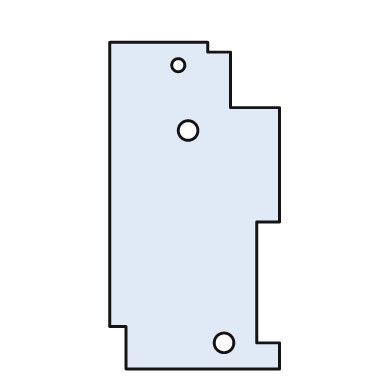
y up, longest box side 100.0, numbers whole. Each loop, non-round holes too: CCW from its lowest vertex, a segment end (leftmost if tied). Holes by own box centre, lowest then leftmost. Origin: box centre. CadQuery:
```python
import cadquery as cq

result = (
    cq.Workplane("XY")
    .moveTo(-21.0, -50.0)
    .lineTo(26.0, -50.0)
    .lineTo(26.0, -42.0)
    .lineTo(19.0, -42.0)
    .lineTo(19.0, -5.0)
    .lineTo(26.0, -5.0)
    .lineTo(26.0, 30.0)
    .lineTo(11.0, 30.0)
    .lineTo(11.0, 47.0)
    .lineTo(4.0, 47.0)
    .lineTo(4.0, 50.0)
    .lineTo(-26.0, 50.0)
    .lineTo(-26.0, -37.0)
    .lineTo(-21.0, -37.0)
    .close()
    .moveTo(9.0, -42.0)
    .circle(3.0)
    .moveTo(-2.0, 23.0)
    .circle(3.0)
    .moveTo(-5.0, 43.0)
    .circle(2.0)
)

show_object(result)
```